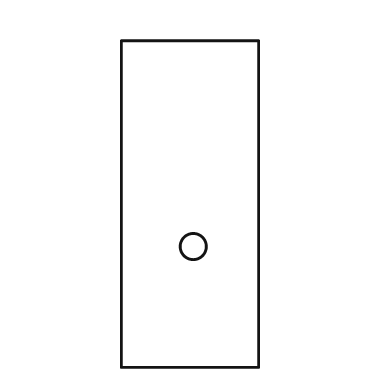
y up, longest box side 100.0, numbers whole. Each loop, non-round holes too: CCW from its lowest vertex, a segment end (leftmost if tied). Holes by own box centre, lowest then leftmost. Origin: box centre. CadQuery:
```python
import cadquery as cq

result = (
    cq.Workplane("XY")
    .moveTo(-21.0, -50.0)
    .lineTo(21.0, -50.0)
    .lineTo(21.0, 50.0)
    .lineTo(-21.0, 50.0)
    .close()
    .moveTo(1.0, -13.0)
    .circle(4.0)
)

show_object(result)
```